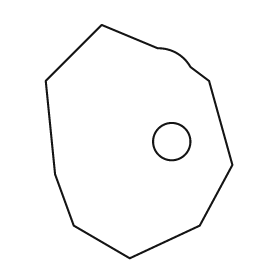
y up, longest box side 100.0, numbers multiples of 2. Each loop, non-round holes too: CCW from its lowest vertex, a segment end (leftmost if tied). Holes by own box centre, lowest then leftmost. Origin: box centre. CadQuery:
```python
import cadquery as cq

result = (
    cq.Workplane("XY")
    .moveTo(-4.0, -50.0)
    .lineTo(26.0, -36.0)
    .lineTo(40.0, -10.0)
    .lineTo(30.0, 26.0)
    .lineTo(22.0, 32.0)
    .threePointArc((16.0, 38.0), (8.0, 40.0))
    .lineTo(-16.0, 50.0)
    .lineTo(-40.0, 26.0)
    .lineTo(-36.0, -14.0)
    .lineTo(-28.0, -36.0)
    .close()
    .moveTo(14.0, 0.0)
    .circle(8.0)
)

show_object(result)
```